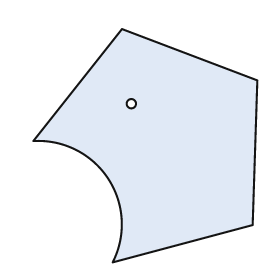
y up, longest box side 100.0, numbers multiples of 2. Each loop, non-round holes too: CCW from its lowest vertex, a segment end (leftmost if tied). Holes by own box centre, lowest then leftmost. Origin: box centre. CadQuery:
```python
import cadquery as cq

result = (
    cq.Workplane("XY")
    .moveTo(-14.0, -50.0)
    .lineTo(46.0, -34.0)
    .lineTo(48.0, 28.0)
    .lineTo(-10.0, 50.0)
    .lineTo(-48.0, 2.0)
    .threePointArc((-16.0, -14.0), (-14.0, -50.0))
    .close()
    .moveTo(-6.0, 18.0)
    .circle(2.0)
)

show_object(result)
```